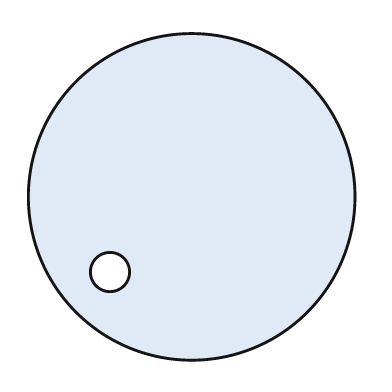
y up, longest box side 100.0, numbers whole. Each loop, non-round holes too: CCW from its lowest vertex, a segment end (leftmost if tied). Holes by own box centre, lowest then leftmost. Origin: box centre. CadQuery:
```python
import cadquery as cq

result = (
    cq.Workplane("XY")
    .moveTo(0.0, 0.0)
    .circle(50.0)
    .moveTo(-25.0, -23.0)
    .circle(6.0)
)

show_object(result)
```